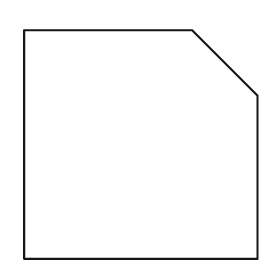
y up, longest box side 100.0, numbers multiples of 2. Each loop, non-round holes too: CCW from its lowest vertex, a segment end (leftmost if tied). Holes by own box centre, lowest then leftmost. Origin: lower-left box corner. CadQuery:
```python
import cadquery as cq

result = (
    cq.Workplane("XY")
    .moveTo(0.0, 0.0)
    .lineTo(100.0, 0.0)
    .lineTo(100.0, 70.0)
    .lineTo(72.0, 98.0)
    .lineTo(0.0, 98.0)
    .close()
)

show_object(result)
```